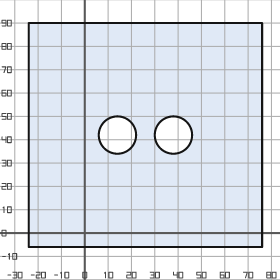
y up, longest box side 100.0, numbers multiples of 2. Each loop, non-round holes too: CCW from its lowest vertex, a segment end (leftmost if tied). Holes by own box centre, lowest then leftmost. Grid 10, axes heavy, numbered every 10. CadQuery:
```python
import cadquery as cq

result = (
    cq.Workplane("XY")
    .moveTo(-24.0, -6.0)
    .lineTo(76.0, -6.0)
    .lineTo(76.0, 90.0)
    .lineTo(-24.0, 90.0)
    .close()
    .moveTo(14.0, 42.0)
    .circle(8.0)
    .moveTo(38.0, 42.0)
    .circle(8.0)
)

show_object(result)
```